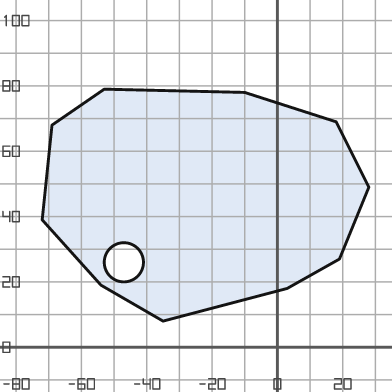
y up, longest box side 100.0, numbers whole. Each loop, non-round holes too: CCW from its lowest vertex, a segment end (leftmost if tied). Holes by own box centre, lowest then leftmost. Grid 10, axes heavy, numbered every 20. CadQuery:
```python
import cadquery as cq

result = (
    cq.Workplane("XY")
    .moveTo(-35.0, 8.0)
    .lineTo(3.0, 18.0)
    .lineTo(19.0, 27.0)
    .lineTo(28.0, 49.0)
    .lineTo(18.0, 69.0)
    .lineTo(-10.0, 78.0)
    .lineTo(-53.0, 79.0)
    .lineTo(-69.0, 68.0)
    .lineTo(-72.0, 39.0)
    .lineTo(-54.0, 19.0)
    .close()
    .moveTo(-47.0, 26.0)
    .circle(6.0)
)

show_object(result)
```